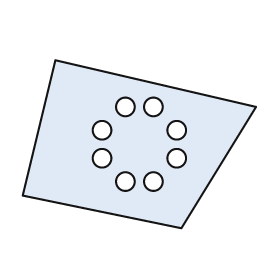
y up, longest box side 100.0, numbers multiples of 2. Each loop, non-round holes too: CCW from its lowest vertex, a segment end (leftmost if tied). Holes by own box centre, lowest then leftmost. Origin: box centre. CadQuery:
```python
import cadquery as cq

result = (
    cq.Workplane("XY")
    .moveTo(18.0, -36.0)
    .lineTo(50.0, 16.0)
    .lineTo(-36.0, 36.0)
    .lineTo(-50.0, -22.0)
    .close()
    .moveTo(-6.0, -16.0)
    .circle(4.0)
    .moveTo(6.0, -16.0)
    .circle(4.0)
    .moveTo(-16.0, -6.0)
    .circle(4.0)
    .moveTo(16.0, -6.0)
    .circle(4.0)
    .moveTo(-16.0, 6.0)
    .circle(4.0)
    .moveTo(16.0, 6.0)
    .circle(4.0)
    .moveTo(-6.0, 16.0)
    .circle(4.0)
    .moveTo(6.0, 16.0)
    .circle(4.0)
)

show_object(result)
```